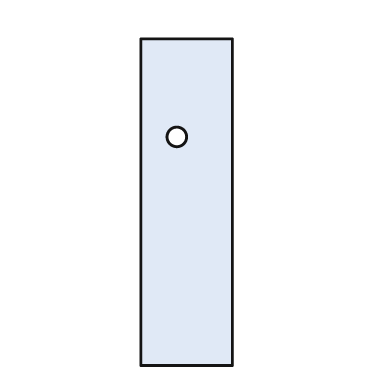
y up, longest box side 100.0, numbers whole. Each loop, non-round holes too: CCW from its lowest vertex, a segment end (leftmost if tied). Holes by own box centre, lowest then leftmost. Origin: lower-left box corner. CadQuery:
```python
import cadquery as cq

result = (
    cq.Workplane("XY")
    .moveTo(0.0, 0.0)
    .lineTo(28.0, 0.0)
    .lineTo(28.0, 100.0)
    .lineTo(0.0, 100.0)
    .close()
    .moveTo(11.0, 70.0)
    .circle(3.0)
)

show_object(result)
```